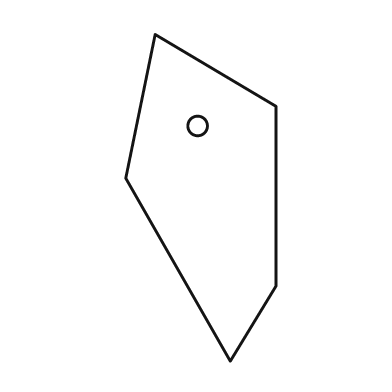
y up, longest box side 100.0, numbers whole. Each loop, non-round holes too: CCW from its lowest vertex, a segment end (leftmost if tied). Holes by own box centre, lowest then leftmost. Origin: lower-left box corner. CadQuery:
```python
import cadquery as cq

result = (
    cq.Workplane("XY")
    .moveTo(32.0, 0.0)
    .lineTo(46.0, 23.0)
    .lineTo(46.0, 78.0)
    .lineTo(9.0, 100.0)
    .lineTo(0.0, 56.0)
    .close()
    .moveTo(22.0, 72.0)
    .circle(3.0)
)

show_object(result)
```